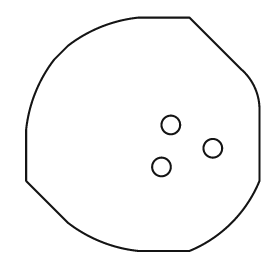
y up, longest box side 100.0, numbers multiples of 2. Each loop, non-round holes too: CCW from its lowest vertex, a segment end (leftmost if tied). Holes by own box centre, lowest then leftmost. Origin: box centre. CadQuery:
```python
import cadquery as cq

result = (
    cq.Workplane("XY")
    .moveTo(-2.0, -50.0)
    .lineTo(20.0, -50.0)
    .threePointArc((38.0, -38.0), (50.0, -20.0))
    .lineTo(50.0, 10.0)
    .threePointArc((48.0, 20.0), (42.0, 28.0))
    .lineTo(20.0, 50.0)
    .lineTo(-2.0, 50.0)
    .threePointArc((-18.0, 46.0), (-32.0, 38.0))
    .lineTo(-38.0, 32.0)
    .threePointArc((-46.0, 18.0), (-50.0, 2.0))
    .lineTo(-50.0, -20.0)
    .lineTo(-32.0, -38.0)
    .threePointArc((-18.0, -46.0), (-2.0, -50.0))
    .close()
    .moveTo(8.0, -14.0)
    .circle(4.0)
    .moveTo(30.0, -6.0)
    .circle(4.0)
    .moveTo(12.0, 4.0)
    .circle(4.0)
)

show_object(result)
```